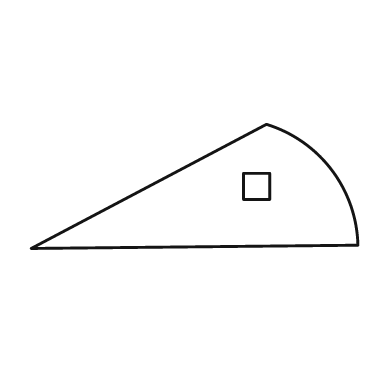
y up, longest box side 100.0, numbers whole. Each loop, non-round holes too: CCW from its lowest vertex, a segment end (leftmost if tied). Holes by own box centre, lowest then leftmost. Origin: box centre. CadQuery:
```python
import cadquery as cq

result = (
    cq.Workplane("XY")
    .moveTo(-50.0, -19.0)
    .lineTo(50.0, -18.0)
    .threePointArc((42.0, 5.0), (22.0, 19.0))
    .close()
    .moveTo(15.0, -4.0)
    .lineTo(23.0, -4.0)
    .lineTo(23.0, 4.0)
    .lineTo(15.0, 4.0)
    .close()
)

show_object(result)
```